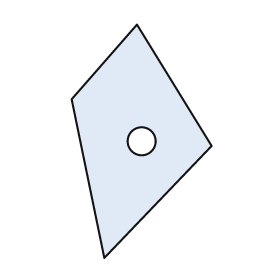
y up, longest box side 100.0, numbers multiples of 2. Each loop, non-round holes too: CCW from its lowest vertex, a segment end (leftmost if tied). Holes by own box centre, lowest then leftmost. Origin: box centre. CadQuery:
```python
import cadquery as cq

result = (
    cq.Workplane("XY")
    .moveTo(-16.0, -50.0)
    .lineTo(30.0, -2.0)
    .lineTo(-2.0, 50.0)
    .lineTo(-30.0, 18.0)
    .close()
    .moveTo(0.0, 0.0)
    .circle(6.0)
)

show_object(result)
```